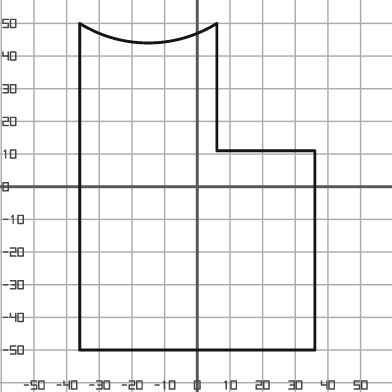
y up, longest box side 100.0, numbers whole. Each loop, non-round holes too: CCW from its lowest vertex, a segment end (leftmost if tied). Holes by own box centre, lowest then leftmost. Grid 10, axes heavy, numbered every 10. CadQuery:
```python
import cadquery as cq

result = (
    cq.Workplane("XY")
    .moveTo(-36.0, -50.0)
    .lineTo(36.0, -50.0)
    .lineTo(36.0, 11.0)
    .lineTo(6.0, 11.0)
    .lineTo(6.0, 50.0)
    .threePointArc((-15.0, 44.0), (-36.0, 50.0))
    .close()
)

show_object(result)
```